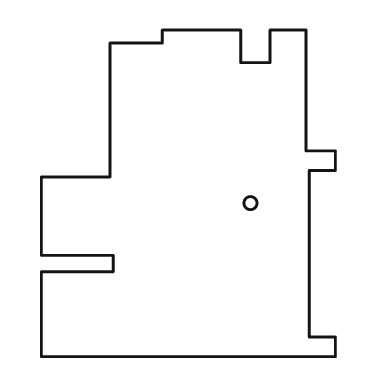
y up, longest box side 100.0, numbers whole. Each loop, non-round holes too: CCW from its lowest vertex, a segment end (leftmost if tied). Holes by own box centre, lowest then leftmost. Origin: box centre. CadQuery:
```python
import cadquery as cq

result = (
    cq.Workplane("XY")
    .moveTo(-45.0, -50.0)
    .lineTo(45.0, -50.0)
    .lineTo(45.0, -44.0)
    .lineTo(37.0, -44.0)
    .lineTo(37.0, 7.0)
    .lineTo(45.0, 7.0)
    .lineTo(45.0, 13.0)
    .lineTo(36.0, 13.0)
    .lineTo(36.0, 50.0)
    .lineTo(25.0, 50.0)
    .lineTo(25.0, 40.0)
    .lineTo(16.0, 40.0)
    .lineTo(16.0, 50.0)
    .lineTo(-8.0, 50.0)
    .lineTo(-8.0, 46.0)
    .lineTo(-24.0, 46.0)
    .lineTo(-24.0, 5.0)
    .lineTo(-45.0, 5.0)
    .lineTo(-45.0, -19.0)
    .lineTo(-23.0, -19.0)
    .lineTo(-23.0, -24.0)
    .lineTo(-45.0, -24.0)
    .close()
    .moveTo(19.0, -3.0)
    .circle(2.0)
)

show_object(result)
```